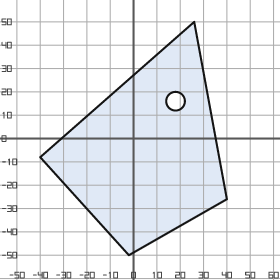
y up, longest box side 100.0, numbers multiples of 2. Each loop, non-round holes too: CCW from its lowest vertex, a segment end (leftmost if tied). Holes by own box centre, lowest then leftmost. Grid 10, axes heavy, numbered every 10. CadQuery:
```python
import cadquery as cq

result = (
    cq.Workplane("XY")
    .moveTo(-2.0, -50.0)
    .lineTo(40.0, -26.0)
    .lineTo(26.0, 50.0)
    .lineTo(-40.0, -8.0)
    .close()
    .moveTo(18.0, 16.0)
    .circle(4.0)
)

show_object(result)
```